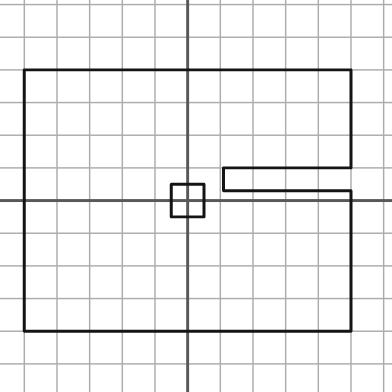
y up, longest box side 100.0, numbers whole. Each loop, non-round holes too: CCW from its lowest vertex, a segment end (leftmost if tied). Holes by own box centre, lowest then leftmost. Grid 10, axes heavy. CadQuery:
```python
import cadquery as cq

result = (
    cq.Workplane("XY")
    .moveTo(-50.0, -40.0)
    .lineTo(50.0, -40.0)
    .lineTo(50.0, 3.0)
    .lineTo(11.0, 3.0)
    .lineTo(11.0, 10.0)
    .lineTo(50.0, 10.0)
    .lineTo(50.0, 40.0)
    .lineTo(-50.0, 40.0)
    .close()
    .moveTo(-5.0, -5.0)
    .lineTo(5.0, -5.0)
    .lineTo(5.0, 5.0)
    .lineTo(-5.0, 5.0)
    .close()
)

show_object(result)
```